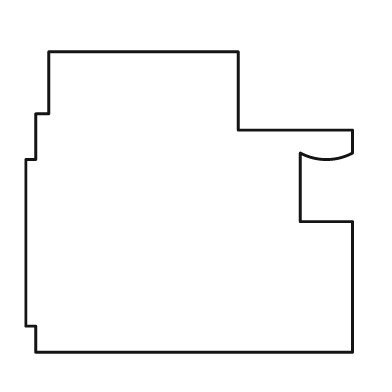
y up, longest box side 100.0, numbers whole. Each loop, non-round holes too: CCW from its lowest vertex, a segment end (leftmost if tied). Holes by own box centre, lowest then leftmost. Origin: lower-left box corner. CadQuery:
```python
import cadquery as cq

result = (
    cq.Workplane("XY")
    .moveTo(3.0, 0.0)
    .lineTo(100.0, 0.0)
    .lineTo(100.0, 40.0)
    .lineTo(84.0, 40.0)
    .lineTo(84.0, 61.0)
    .threePointArc((92.0, 59.0), (100.0, 61.0))
    .lineTo(100.0, 68.0)
    .lineTo(65.0, 68.0)
    .lineTo(65.0, 92.0)
    .lineTo(7.0, 92.0)
    .lineTo(7.0, 73.0)
    .lineTo(3.0, 73.0)
    .lineTo(3.0, 59.0)
    .lineTo(0.0, 59.0)
    .lineTo(0.0, 8.0)
    .lineTo(3.0, 8.0)
    .close()
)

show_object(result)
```